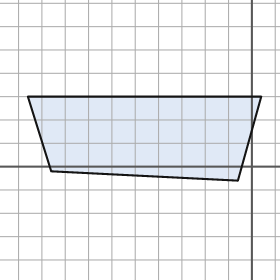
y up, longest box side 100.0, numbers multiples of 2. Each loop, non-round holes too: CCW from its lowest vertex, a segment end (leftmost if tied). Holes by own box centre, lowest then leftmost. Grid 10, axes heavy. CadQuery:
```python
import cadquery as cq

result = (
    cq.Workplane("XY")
    .moveTo(-6.0, -6.0)
    .lineTo(4.0, 30.0)
    .lineTo(-96.0, 30.0)
    .lineTo(-86.0, -2.0)
    .close()
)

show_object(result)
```